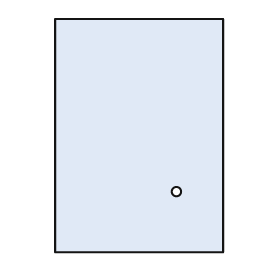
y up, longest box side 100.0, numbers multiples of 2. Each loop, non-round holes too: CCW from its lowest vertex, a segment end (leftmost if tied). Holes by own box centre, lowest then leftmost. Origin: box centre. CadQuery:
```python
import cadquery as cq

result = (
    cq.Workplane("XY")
    .moveTo(-36.0, -50.0)
    .lineTo(36.0, -50.0)
    .lineTo(36.0, 50.0)
    .lineTo(-36.0, 50.0)
    .close()
    .moveTo(16.0, -24.0)
    .circle(2.0)
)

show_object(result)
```